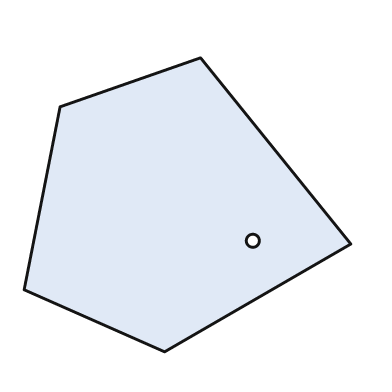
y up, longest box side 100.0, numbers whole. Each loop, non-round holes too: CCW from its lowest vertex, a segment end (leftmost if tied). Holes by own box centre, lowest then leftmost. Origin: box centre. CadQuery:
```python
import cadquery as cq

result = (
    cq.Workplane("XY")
    .moveTo(-7.0, -45.0)
    .lineTo(50.0, -12.0)
    .lineTo(4.0, 45.0)
    .lineTo(-39.0, 30.0)
    .lineTo(-50.0, -26.0)
    .close()
    .moveTo(20.0, -11.0)
    .circle(2.0)
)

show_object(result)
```